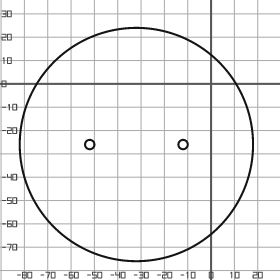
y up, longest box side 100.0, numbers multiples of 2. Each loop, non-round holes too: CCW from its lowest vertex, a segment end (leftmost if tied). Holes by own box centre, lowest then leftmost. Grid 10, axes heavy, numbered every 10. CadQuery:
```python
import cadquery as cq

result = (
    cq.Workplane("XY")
    .moveTo(-32.0, -26.0)
    .circle(50.0)
    .moveTo(-52.0, -26.0)
    .circle(2.0)
    .moveTo(-12.0, -26.0)
    .circle(2.0)
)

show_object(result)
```